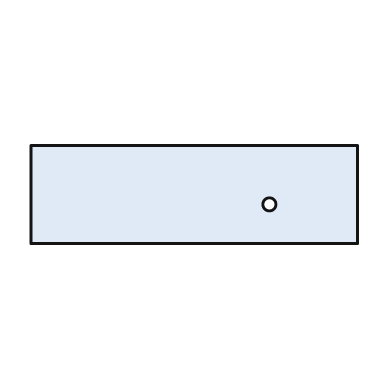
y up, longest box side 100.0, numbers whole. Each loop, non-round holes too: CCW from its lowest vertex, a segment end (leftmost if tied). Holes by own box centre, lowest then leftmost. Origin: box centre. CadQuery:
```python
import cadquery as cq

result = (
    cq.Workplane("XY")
    .moveTo(-50.0, -15.0)
    .lineTo(50.0, -15.0)
    .lineTo(50.0, 15.0)
    .lineTo(-50.0, 15.0)
    .close()
    .moveTo(23.0, -3.0)
    .circle(2.0)
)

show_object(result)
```